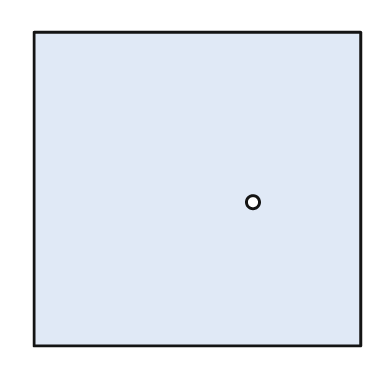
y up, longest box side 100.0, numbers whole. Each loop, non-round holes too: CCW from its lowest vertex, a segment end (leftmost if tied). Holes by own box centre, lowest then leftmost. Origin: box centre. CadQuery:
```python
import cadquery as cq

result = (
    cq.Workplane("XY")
    .moveTo(-50.0, -48.0)
    .lineTo(50.0, -48.0)
    .lineTo(50.0, 48.0)
    .lineTo(-50.0, 48.0)
    .close()
    .moveTo(17.0, -4.0)
    .circle(2.0)
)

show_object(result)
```